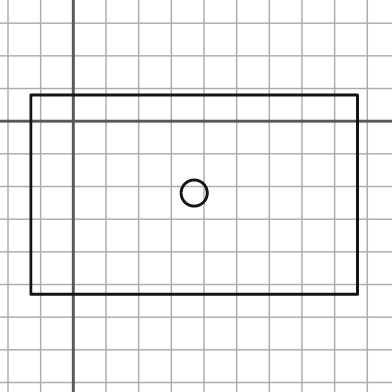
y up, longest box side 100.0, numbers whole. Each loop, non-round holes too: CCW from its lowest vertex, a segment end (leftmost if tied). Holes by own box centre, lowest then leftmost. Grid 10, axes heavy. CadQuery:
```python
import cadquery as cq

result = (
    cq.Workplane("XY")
    .moveTo(-13.0, -53.0)
    .lineTo(87.0, -53.0)
    .lineTo(87.0, 8.0)
    .lineTo(-13.0, 8.0)
    .close()
    .moveTo(37.0, -22.0)
    .circle(4.0)
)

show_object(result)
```